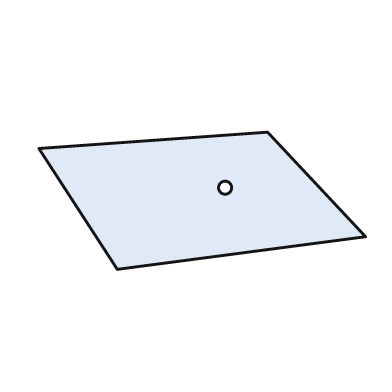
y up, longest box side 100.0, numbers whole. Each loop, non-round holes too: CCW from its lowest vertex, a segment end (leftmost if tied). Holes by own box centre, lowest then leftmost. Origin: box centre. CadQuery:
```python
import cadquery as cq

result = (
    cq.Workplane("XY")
    .moveTo(-26.0, -21.0)
    .lineTo(50.0, -11.0)
    .lineTo(20.0, 21.0)
    .lineTo(-50.0, 16.0)
    .close()
    .moveTo(7.0, 4.0)
    .circle(2.0)
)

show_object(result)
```